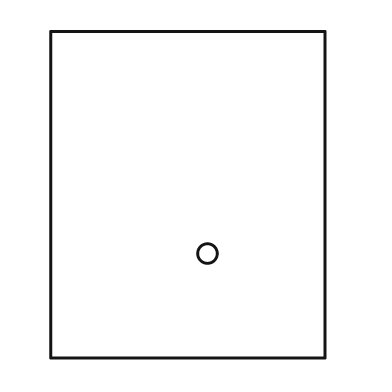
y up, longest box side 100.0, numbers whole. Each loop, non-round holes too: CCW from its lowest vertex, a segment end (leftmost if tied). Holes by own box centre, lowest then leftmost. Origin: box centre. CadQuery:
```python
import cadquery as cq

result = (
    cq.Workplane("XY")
    .moveTo(-42.0, -50.0)
    .lineTo(42.0, -50.0)
    .lineTo(42.0, 50.0)
    .lineTo(-42.0, 50.0)
    .close()
    .moveTo(6.0, -18.0)
    .circle(3.0)
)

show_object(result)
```